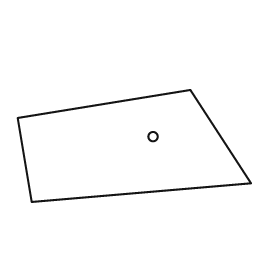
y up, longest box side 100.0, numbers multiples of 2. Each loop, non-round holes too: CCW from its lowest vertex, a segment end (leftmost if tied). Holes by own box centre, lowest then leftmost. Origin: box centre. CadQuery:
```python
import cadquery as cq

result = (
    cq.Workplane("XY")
    .moveTo(-44.0, -24.0)
    .lineTo(50.0, -16.0)
    .lineTo(24.0, 24.0)
    .lineTo(-50.0, 12.0)
    .close()
    .moveTo(8.0, 4.0)
    .circle(2.0)
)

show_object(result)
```